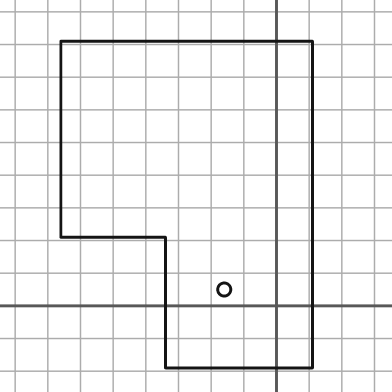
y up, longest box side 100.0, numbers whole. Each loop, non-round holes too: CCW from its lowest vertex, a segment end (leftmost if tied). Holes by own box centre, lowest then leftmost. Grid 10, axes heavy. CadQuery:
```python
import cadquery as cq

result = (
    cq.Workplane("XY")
    .moveTo(-34.0, -19.0)
    .lineTo(11.0, -19.0)
    .lineTo(11.0, 81.0)
    .lineTo(-66.0, 81.0)
    .lineTo(-66.0, 21.0)
    .lineTo(-34.0, 21.0)
    .close()
    .moveTo(-16.0, 5.0)
    .circle(2.0)
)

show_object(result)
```